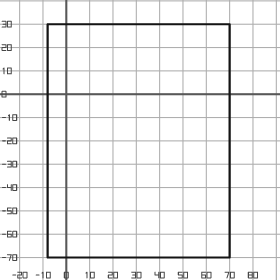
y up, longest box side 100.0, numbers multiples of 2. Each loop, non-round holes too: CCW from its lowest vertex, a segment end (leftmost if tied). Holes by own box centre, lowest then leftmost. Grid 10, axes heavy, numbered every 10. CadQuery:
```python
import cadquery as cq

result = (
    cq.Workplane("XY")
    .moveTo(-8.0, -70.0)
    .lineTo(70.0, -70.0)
    .lineTo(70.0, 30.0)
    .lineTo(-8.0, 30.0)
    .close()
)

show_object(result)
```